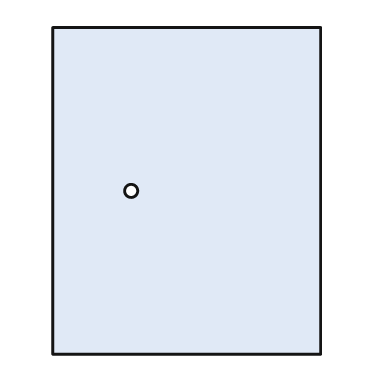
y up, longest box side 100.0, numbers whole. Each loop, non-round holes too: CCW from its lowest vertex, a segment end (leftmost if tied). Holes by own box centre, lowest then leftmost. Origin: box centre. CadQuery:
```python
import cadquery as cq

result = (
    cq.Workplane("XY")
    .moveTo(-41.0, -50.0)
    .lineTo(41.0, -50.0)
    .lineTo(41.0, 50.0)
    .lineTo(-41.0, 50.0)
    .close()
    .moveTo(-17.0, 0.0)
    .circle(2.0)
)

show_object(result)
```